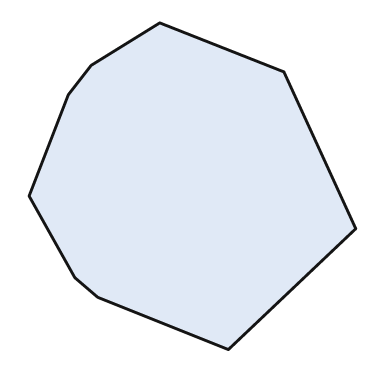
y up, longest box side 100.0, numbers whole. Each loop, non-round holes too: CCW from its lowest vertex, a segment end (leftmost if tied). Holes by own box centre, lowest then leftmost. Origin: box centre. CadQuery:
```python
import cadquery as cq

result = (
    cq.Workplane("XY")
    .moveTo(11.0, -50.0)
    .lineTo(50.0, -13.0)
    .lineTo(28.0, 35.0)
    .lineTo(-10.0, 50.0)
    .lineTo(-31.0, 37.0)
    .lineTo(-38.0, 28.0)
    .lineTo(-50.0, -3.0)
    .lineTo(-36.0, -28.0)
    .lineTo(-29.0, -34.0)
    .close()
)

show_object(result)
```